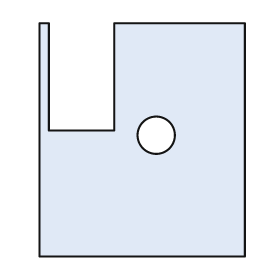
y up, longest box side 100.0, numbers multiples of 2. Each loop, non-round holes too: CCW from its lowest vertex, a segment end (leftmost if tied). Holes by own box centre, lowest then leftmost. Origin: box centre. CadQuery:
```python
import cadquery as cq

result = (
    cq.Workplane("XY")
    .moveTo(-44.0, -50.0)
    .lineTo(44.0, -50.0)
    .lineTo(44.0, 50.0)
    .lineTo(-12.0, 50.0)
    .lineTo(-12.0, 4.0)
    .lineTo(-40.0, 4.0)
    .lineTo(-40.0, 50.0)
    .lineTo(-44.0, 50.0)
    .close()
    .moveTo(6.0, 2.0)
    .circle(8.0)
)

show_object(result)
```